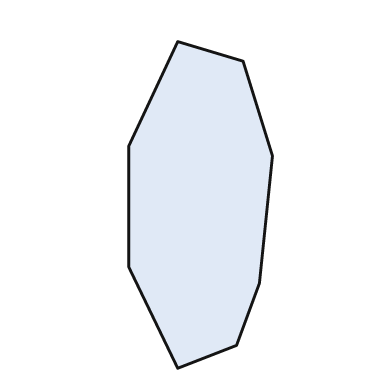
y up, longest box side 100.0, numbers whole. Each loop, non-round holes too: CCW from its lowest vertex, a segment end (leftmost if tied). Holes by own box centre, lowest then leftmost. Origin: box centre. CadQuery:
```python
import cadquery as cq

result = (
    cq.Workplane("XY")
    .moveTo(-7.0, -50.0)
    .lineTo(11.0, -43.0)
    .lineTo(18.0, -24.0)
    .lineTo(22.0, 15.0)
    .lineTo(13.0, 44.0)
    .lineTo(-7.0, 50.0)
    .lineTo(-22.0, 18.0)
    .lineTo(-22.0, -19.0)
    .close()
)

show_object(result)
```